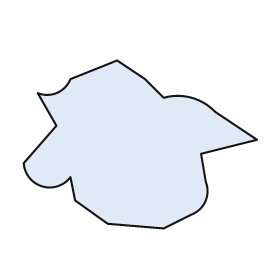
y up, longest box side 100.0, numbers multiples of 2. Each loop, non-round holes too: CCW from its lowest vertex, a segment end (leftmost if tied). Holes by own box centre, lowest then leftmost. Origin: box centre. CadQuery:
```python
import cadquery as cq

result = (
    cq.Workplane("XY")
    .moveTo(10.0, -36.0)
    .lineTo(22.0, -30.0)
    .threePointArc((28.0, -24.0), (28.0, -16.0))
    .lineTo(26.0, -4.0)
    .lineTo(50.0, 2.0)
    .lineTo(32.0, 14.0)
    .threePointArc((22.0, 20.0), (10.0, 20.0))
    .lineTo(2.0, 28.0)
    .lineTo(-10.0, 36.0)
    .lineTo(-30.0, 28.0)
    .threePointArc((-36.0, 22.0), (-44.0, 22.0))
    .lineTo(-36.0, 8.0)
    .lineTo(-50.0, -8.0)
    .threePointArc((-42.0, -18.0), (-30.0, -14.0))
    .lineTo(-28.0, -24.0)
    .lineTo(-14.0, -34.0)
    .close()
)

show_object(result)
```